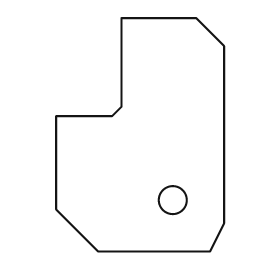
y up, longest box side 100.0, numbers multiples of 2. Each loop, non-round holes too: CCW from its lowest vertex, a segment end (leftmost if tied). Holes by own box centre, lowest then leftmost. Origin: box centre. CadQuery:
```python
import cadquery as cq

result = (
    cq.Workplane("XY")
    .moveTo(-18.0, -50.0)
    .lineTo(30.0, -50.0)
    .lineTo(36.0, -38.0)
    .lineTo(36.0, 38.0)
    .lineTo(24.0, 50.0)
    .lineTo(-8.0, 50.0)
    .lineTo(-8.0, 12.0)
    .lineTo(-12.0, 8.0)
    .lineTo(-36.0, 8.0)
    .lineTo(-36.0, -32.0)
    .close()
    .moveTo(14.0, -28.0)
    .circle(6.0)
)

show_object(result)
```